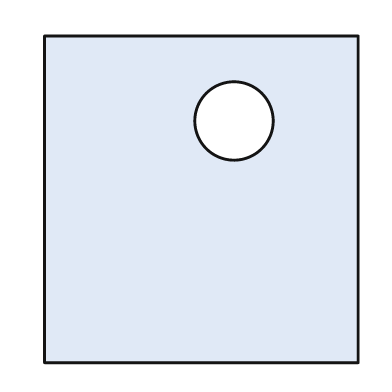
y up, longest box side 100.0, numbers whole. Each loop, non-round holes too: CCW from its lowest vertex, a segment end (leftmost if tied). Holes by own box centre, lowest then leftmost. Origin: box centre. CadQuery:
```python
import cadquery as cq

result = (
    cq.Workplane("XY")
    .moveTo(-48.0, -50.0)
    .lineTo(48.0, -50.0)
    .lineTo(48.0, 50.0)
    .lineTo(-48.0, 50.0)
    .close()
    .moveTo(10.0, 24.0)
    .circle(12.0)
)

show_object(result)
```